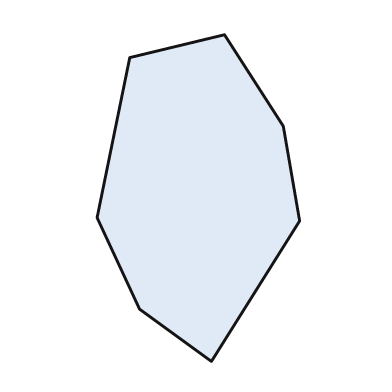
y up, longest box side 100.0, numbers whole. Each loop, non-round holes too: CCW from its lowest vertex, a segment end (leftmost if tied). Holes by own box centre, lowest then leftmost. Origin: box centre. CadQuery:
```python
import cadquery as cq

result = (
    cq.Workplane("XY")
    .moveTo(4.0, -50.0)
    .lineTo(31.0, -7.0)
    .lineTo(26.0, 22.0)
    .lineTo(8.0, 50.0)
    .lineTo(-21.0, 43.0)
    .lineTo(-31.0, -6.0)
    .lineTo(-18.0, -34.0)
    .close()
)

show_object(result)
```